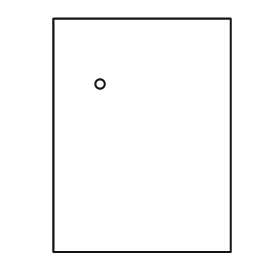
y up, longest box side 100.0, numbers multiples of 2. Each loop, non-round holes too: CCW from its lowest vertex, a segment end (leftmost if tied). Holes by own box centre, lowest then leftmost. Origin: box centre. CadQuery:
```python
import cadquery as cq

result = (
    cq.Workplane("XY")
    .moveTo(-38.0, -50.0)
    .lineTo(38.0, -50.0)
    .lineTo(38.0, 50.0)
    .lineTo(-38.0, 50.0)
    .close()
    .moveTo(-18.0, 22.0)
    .circle(2.0)
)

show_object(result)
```